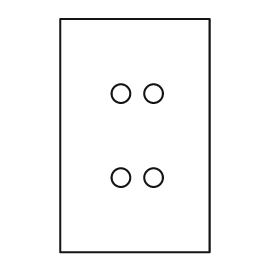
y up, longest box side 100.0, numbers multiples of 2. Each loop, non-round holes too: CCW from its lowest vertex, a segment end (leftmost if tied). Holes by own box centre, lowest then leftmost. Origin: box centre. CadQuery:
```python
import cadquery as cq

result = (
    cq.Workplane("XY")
    .moveTo(-32.0, -50.0)
    .lineTo(32.0, -50.0)
    .lineTo(32.0, 50.0)
    .lineTo(-32.0, 50.0)
    .close()
    .moveTo(-6.0, -18.0)
    .circle(4.0)
    .moveTo(8.0, -18.0)
    .circle(4.0)
    .moveTo(-6.0, 18.0)
    .circle(4.0)
    .moveTo(8.0, 18.0)
    .circle(4.0)
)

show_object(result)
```